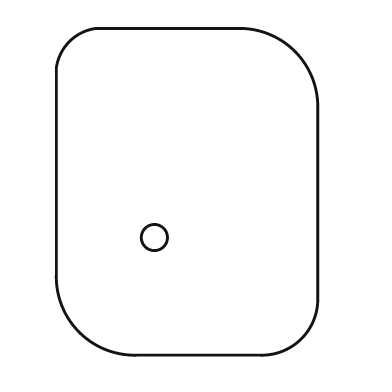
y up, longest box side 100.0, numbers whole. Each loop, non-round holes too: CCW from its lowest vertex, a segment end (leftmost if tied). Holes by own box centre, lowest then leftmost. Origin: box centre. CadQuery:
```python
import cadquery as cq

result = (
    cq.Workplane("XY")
    .moveTo(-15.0, -50.0)
    .lineTo(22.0, -50.0)
    .threePointArc((35.0, -45.0), (40.0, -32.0))
    .lineTo(40.0, 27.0)
    .threePointArc((33.0, 43.0), (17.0, 50.0))
    .lineTo(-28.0, 50.0)
    .threePointArc((-36.0, 46.0), (-40.0, 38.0))
    .lineTo(-40.0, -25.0)
    .threePointArc((-33.0, -43.0), (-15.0, -50.0))
    .close()
    .moveTo(-10.0, -14.0)
    .circle(4.0)
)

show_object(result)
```